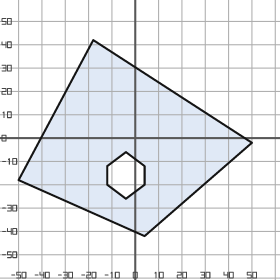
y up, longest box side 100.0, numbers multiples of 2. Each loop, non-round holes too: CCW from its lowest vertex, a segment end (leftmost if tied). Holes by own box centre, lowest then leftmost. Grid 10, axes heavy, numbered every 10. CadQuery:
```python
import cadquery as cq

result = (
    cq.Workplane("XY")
    .moveTo(4.0, -42.0)
    .lineTo(50.0, -2.0)
    .lineTo(-18.0, 42.0)
    .lineTo(-50.0, -18.0)
    .close()
    .moveTo(-4.0, -26.0)
    .lineTo(4.0, -20.0)
    .lineTo(4.0, -12.0)
    .lineTo(-4.0, -6.0)
    .lineTo(-12.0, -12.0)
    .lineTo(-12.0, -20.0)
    .close()
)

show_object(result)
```